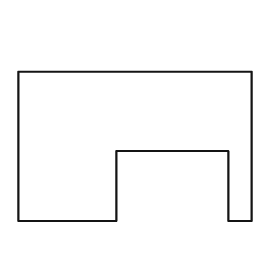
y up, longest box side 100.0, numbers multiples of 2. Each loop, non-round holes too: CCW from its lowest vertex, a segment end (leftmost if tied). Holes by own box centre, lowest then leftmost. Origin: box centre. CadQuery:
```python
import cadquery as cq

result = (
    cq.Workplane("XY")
    .moveTo(-50.0, -32.0)
    .lineTo(-8.0, -32.0)
    .lineTo(-8.0, -2.0)
    .lineTo(40.0, -2.0)
    .lineTo(40.0, -32.0)
    .lineTo(50.0, -32.0)
    .lineTo(50.0, 32.0)
    .lineTo(-50.0, 32.0)
    .close()
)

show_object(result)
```